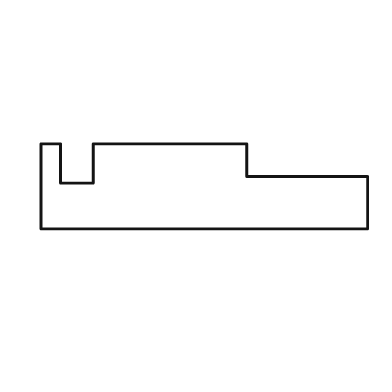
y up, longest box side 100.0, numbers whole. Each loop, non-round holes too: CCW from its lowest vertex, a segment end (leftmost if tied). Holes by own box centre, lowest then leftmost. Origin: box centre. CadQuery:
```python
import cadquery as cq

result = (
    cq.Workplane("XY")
    .moveTo(-50.0, -13.0)
    .lineTo(50.0, -13.0)
    .lineTo(50.0, 3.0)
    .lineTo(13.0, 3.0)
    .lineTo(13.0, 13.0)
    .lineTo(-34.0, 13.0)
    .lineTo(-34.0, 1.0)
    .lineTo(-44.0, 1.0)
    .lineTo(-44.0, 13.0)
    .lineTo(-50.0, 13.0)
    .close()
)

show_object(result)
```